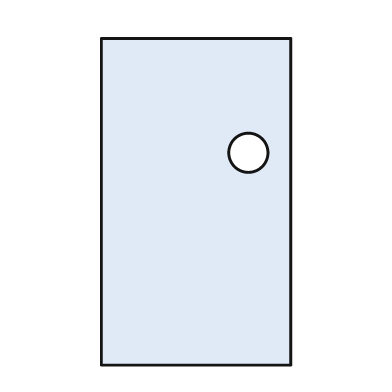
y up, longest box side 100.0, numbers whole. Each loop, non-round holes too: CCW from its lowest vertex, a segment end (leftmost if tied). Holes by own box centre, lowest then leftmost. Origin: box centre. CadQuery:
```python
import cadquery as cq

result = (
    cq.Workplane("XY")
    .moveTo(-29.0, -50.0)
    .lineTo(29.0, -50.0)
    .lineTo(29.0, 50.0)
    .lineTo(-29.0, 50.0)
    .close()
    .moveTo(16.0, 15.0)
    .circle(6.0)
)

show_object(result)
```